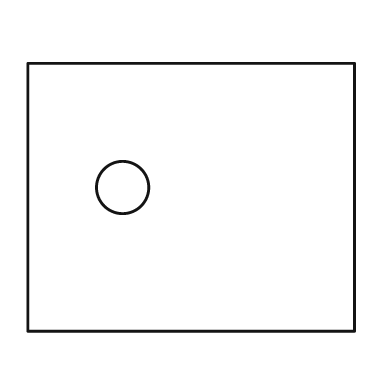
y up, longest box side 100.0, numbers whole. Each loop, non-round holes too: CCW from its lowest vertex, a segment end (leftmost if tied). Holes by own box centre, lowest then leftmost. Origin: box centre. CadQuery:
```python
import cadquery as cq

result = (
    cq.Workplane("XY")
    .moveTo(-50.0, -41.0)
    .lineTo(50.0, -41.0)
    .lineTo(50.0, 41.0)
    .lineTo(-50.0, 41.0)
    .close()
    .moveTo(-21.0, 3.0)
    .circle(8.0)
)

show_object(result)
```